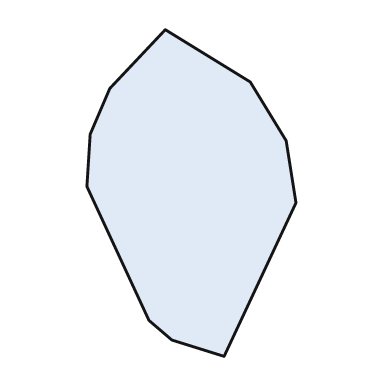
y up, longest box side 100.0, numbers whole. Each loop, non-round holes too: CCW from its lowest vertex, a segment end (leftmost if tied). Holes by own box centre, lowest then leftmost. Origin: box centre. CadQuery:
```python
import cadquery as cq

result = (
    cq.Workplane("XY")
    .moveTo(10.0, -50.0)
    .lineTo(32.0, -3.0)
    .lineTo(29.0, 16.0)
    .lineTo(18.0, 34.0)
    .lineTo(-8.0, 50.0)
    .lineTo(-25.0, 32.0)
    .lineTo(-31.0, 18.0)
    .lineTo(-32.0, 2.0)
    .lineTo(-13.0, -39.0)
    .lineTo(-6.0, -45.0)
    .close()
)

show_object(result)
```